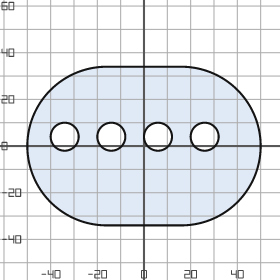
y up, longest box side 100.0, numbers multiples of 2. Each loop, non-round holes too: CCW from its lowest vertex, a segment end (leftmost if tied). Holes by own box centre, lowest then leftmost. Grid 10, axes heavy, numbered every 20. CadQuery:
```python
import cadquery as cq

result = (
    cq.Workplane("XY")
    .moveTo(-16.0, -34.0)
    .lineTo(16.0, -34.0)
    .threePointArc((50.0, 0.0), (16.0, 34.0))
    .lineTo(-16.0, 34.0)
    .threePointArc((-50.0, 0.0), (-16.0, -34.0))
    .close()
    .moveTo(-34.0, 4.0)
    .circle(6.0)
    .moveTo(-14.0, 4.0)
    .circle(6.0)
    .moveTo(6.0, 4.0)
    .circle(6.0)
    .moveTo(26.0, 4.0)
    .circle(6.0)
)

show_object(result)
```